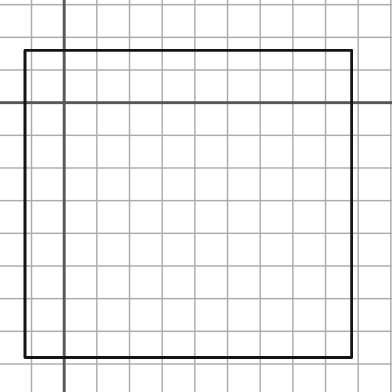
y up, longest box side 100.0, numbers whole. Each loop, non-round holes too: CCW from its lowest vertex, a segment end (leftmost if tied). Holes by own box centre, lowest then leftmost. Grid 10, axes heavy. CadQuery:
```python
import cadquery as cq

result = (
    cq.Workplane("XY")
    .moveTo(-12.0, -78.0)
    .lineTo(88.0, -78.0)
    .lineTo(88.0, 16.0)
    .lineTo(-12.0, 16.0)
    .close()
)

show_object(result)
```